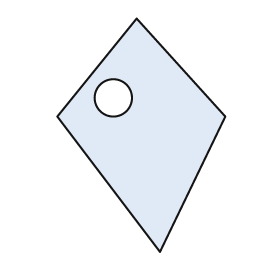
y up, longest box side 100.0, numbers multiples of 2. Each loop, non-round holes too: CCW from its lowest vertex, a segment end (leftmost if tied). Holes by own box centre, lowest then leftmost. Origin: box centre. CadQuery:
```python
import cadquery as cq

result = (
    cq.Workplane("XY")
    .moveTo(8.0, -50.0)
    .lineTo(36.0, 8.0)
    .lineTo(-2.0, 50.0)
    .lineTo(-36.0, 8.0)
    .close()
    .moveTo(-12.0, 16.0)
    .circle(8.0)
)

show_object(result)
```